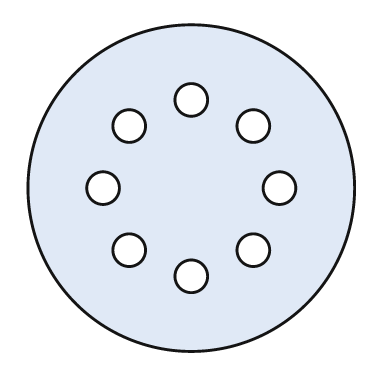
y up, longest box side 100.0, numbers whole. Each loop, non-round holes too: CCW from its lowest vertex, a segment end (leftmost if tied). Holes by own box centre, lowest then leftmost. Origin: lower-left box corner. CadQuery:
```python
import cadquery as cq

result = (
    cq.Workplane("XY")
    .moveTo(50.0, 50.0)
    .circle(50.0)
    .moveTo(50.0, 23.0)
    .circle(5.0)
    .moveTo(31.0, 31.0)
    .circle(5.0)
    .moveTo(69.0, 31.0)
    .circle(5.0)
    .moveTo(23.0, 50.0)
    .circle(5.0)
    .moveTo(77.0, 50.0)
    .circle(5.0)
    .moveTo(31.0, 69.0)
    .circle(5.0)
    .moveTo(69.0, 69.0)
    .circle(5.0)
    .moveTo(50.0, 77.0)
    .circle(5.0)
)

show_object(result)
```